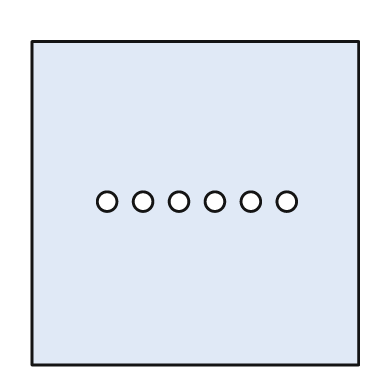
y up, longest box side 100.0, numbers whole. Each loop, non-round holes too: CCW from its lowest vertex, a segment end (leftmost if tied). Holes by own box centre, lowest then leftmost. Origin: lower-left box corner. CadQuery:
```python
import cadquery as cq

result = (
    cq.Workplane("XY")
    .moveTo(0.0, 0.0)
    .lineTo(100.0, 0.0)
    .lineTo(100.0, 99.0)
    .lineTo(0.0, 99.0)
    .close()
    .moveTo(23.0, 50.0)
    .circle(3.0)
    .moveTo(34.0, 50.0)
    .circle(3.0)
    .moveTo(45.0, 50.0)
    .circle(3.0)
    .moveTo(56.0, 50.0)
    .circle(3.0)
    .moveTo(67.0, 50.0)
    .circle(3.0)
    .moveTo(78.0, 50.0)
    .circle(3.0)
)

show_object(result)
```